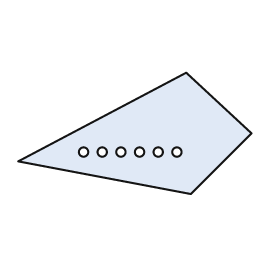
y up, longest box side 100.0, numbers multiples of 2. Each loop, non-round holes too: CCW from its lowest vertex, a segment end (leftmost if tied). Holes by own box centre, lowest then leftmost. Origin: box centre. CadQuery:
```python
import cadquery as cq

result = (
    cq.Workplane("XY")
    .moveTo(24.0, -26.0)
    .lineTo(50.0, 0.0)
    .lineTo(22.0, 26.0)
    .lineTo(-50.0, -12.0)
    .close()
    .moveTo(-22.0, -8.0)
    .circle(2.0)
    .moveTo(-14.0, -8.0)
    .circle(2.0)
    .moveTo(-6.0, -8.0)
    .circle(2.0)
    .moveTo(2.0, -8.0)
    .circle(2.0)
    .moveTo(10.0, -8.0)
    .circle(2.0)
    .moveTo(18.0, -8.0)
    .circle(2.0)
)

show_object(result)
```